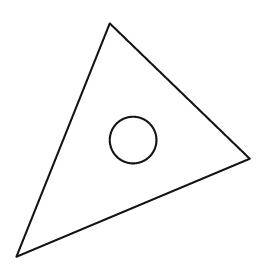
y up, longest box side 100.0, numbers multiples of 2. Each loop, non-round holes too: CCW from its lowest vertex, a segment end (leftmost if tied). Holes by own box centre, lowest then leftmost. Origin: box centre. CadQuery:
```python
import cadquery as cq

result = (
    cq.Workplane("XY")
    .moveTo(-50.0, -50.0)
    .lineTo(50.0, -8.0)
    .lineTo(-10.0, 50.0)
    .close()
    .moveTo(0.0, 0.0)
    .circle(10.0)
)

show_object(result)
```